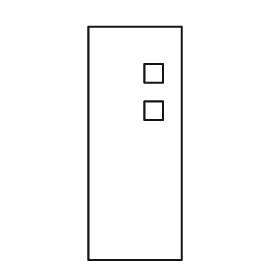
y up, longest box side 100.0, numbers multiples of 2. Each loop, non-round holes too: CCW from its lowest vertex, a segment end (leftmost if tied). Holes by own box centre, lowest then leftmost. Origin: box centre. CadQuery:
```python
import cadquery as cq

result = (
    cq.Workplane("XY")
    .moveTo(-20.0, -50.0)
    .lineTo(20.0, -50.0)
    .lineTo(20.0, 50.0)
    .lineTo(-20.0, 50.0)
    .close()
    .moveTo(4.0, 10.0)
    .lineTo(12.0, 10.0)
    .lineTo(12.0, 18.0)
    .lineTo(4.0, 18.0)
    .close()
    .moveTo(4.0, 26.0)
    .lineTo(12.0, 26.0)
    .lineTo(12.0, 34.0)
    .lineTo(4.0, 34.0)
    .close()
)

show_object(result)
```